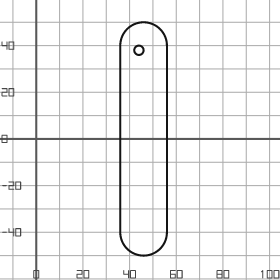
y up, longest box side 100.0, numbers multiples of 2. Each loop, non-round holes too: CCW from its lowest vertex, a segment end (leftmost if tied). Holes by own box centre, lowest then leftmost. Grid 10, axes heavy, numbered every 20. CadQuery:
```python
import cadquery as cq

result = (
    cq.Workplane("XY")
    .moveTo(36.0, -40.0)
    .threePointArc((46.0, -50.0), (56.0, -40.0))
    .lineTo(56.0, 40.0)
    .threePointArc((46.0, 50.0), (36.0, 40.0))
    .close()
    .moveTo(44.0, 38.0)
    .circle(2.0)
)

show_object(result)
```